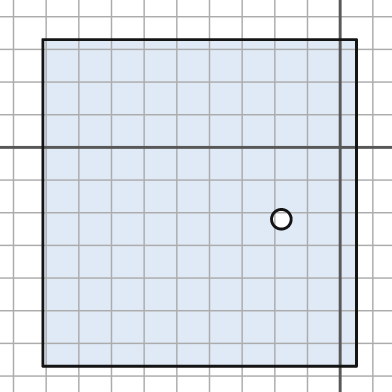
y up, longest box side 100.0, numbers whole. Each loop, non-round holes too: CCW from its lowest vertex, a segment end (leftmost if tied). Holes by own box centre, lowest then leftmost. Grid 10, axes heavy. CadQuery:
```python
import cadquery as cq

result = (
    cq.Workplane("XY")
    .moveTo(-91.0, -67.0)
    .lineTo(5.0, -67.0)
    .lineTo(5.0, 33.0)
    .lineTo(-91.0, 33.0)
    .close()
    .moveTo(-18.0, -22.0)
    .circle(3.0)
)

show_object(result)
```